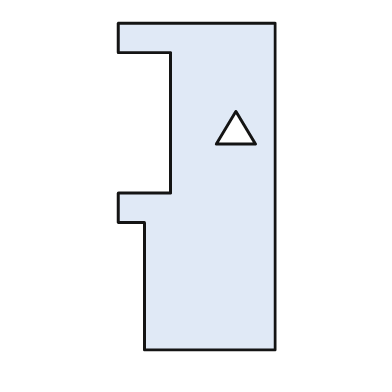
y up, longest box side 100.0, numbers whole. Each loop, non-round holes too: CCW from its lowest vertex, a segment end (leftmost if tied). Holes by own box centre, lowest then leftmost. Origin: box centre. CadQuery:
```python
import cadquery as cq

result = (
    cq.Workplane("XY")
    .moveTo(-16.0, -50.0)
    .lineTo(24.0, -50.0)
    .lineTo(24.0, 50.0)
    .lineTo(-24.0, 50.0)
    .lineTo(-24.0, 41.0)
    .lineTo(-8.0, 41.0)
    .lineTo(-8.0, -2.0)
    .lineTo(-24.0, -2.0)
    .lineTo(-24.0, -11.0)
    .lineTo(-16.0, -11.0)
    .close()
    .moveTo(6.0, 13.0)
    .lineTo(18.0, 13.0)
    .lineTo(12.0, 23.0)
    .close()
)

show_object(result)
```